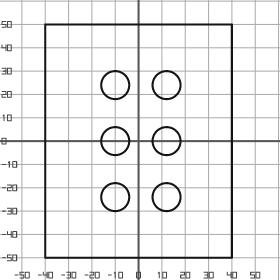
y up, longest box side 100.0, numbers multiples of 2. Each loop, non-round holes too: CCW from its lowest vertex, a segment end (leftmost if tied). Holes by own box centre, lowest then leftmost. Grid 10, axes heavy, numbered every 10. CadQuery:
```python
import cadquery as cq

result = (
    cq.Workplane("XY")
    .moveTo(-40.0, -50.0)
    .lineTo(40.0, -50.0)
    .lineTo(40.0, 50.0)
    .lineTo(-40.0, 50.0)
    .close()
    .moveTo(-10.0, -24.0)
    .circle(6.0)
    .moveTo(12.0, -24.0)
    .circle(6.0)
    .moveTo(-10.0, 0.0)
    .circle(6.0)
    .moveTo(12.0, 0.0)
    .circle(6.0)
    .moveTo(-10.0, 24.0)
    .circle(6.0)
    .moveTo(12.0, 24.0)
    .circle(6.0)
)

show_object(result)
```